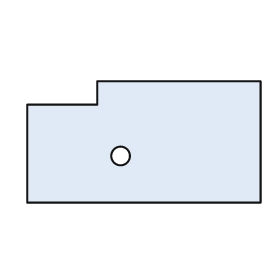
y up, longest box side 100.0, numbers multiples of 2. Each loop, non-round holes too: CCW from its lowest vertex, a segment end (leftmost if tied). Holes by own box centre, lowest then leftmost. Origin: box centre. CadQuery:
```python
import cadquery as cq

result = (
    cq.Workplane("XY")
    .moveTo(-50.0, -26.0)
    .lineTo(50.0, -26.0)
    .lineTo(50.0, 26.0)
    .lineTo(-20.0, 26.0)
    .lineTo(-20.0, 16.0)
    .lineTo(-50.0, 16.0)
    .close()
    .moveTo(-10.0, -6.0)
    .circle(4.0)
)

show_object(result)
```